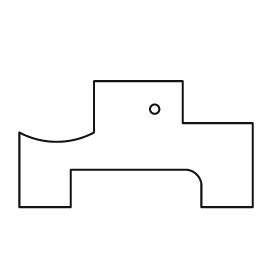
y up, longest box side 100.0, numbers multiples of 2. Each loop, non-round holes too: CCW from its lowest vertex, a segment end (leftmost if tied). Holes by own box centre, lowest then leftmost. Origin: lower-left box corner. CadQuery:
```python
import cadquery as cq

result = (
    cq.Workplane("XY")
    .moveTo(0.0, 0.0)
    .lineTo(22.0, 0.0)
    .lineTo(22.0, 16.0)
    .lineTo(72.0, 16.0)
    .threePointArc((76.0, 14.0), (78.0, 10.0))
    .lineTo(78.0, 0.0)
    .lineTo(100.0, 0.0)
    .lineTo(100.0, 36.0)
    .lineTo(70.0, 36.0)
    .lineTo(70.0, 54.0)
    .lineTo(32.0, 54.0)
    .lineTo(32.0, 32.0)
    .threePointArc((16.0, 28.0), (0.0, 32.0))
    .close()
    .moveTo(58.0, 42.0)
    .circle(2.0)
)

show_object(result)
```